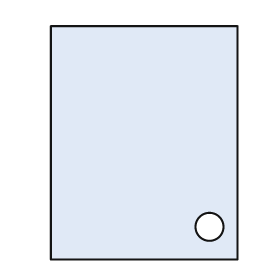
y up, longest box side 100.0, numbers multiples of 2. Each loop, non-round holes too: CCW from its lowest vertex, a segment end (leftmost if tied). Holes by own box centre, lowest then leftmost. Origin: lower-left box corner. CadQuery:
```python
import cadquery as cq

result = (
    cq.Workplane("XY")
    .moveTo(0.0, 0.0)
    .lineTo(80.0, 0.0)
    .lineTo(80.0, 100.0)
    .lineTo(0.0, 100.0)
    .close()
    .moveTo(68.0, 14.0)
    .circle(6.0)
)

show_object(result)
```